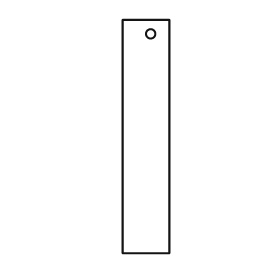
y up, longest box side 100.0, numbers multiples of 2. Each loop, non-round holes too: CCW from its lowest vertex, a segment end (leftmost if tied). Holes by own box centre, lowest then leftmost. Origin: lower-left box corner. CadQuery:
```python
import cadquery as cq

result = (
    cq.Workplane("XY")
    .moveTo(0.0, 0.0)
    .lineTo(20.0, 0.0)
    .lineTo(20.0, 100.0)
    .lineTo(0.0, 100.0)
    .close()
    .moveTo(12.0, 94.0)
    .circle(2.0)
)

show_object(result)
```